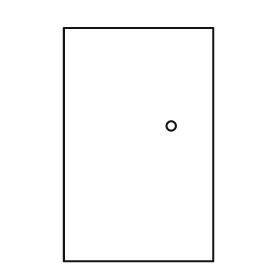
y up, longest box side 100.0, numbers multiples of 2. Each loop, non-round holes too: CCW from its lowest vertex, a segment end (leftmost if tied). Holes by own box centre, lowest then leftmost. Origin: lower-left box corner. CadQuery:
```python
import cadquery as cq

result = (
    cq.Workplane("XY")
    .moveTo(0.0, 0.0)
    .lineTo(64.0, 0.0)
    .lineTo(64.0, 100.0)
    .lineTo(0.0, 100.0)
    .close()
    .moveTo(46.0, 58.0)
    .circle(2.0)
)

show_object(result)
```